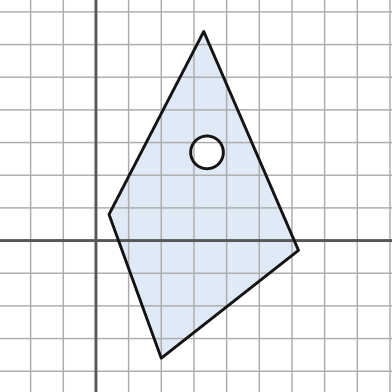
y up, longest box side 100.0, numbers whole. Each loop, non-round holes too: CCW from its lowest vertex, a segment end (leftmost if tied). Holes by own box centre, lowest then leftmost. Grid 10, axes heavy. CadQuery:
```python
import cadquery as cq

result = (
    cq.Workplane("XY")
    .moveTo(20.0, -36.0)
    .lineTo(62.0, -3.0)
    .lineTo(33.0, 64.0)
    .lineTo(4.0, 8.0)
    .close()
    .moveTo(34.0, 27.0)
    .circle(5.0)
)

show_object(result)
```